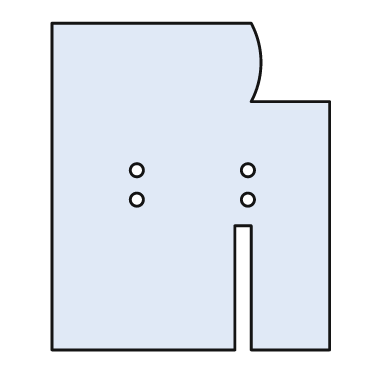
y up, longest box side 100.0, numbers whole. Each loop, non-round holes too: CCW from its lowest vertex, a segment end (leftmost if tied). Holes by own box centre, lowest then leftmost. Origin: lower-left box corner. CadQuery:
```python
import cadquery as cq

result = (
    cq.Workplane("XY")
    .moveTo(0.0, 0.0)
    .lineTo(56.0, 0.0)
    .lineTo(56.0, 38.0)
    .lineTo(61.0, 38.0)
    .lineTo(61.0, 0.0)
    .lineTo(85.0, 0.0)
    .lineTo(85.0, 76.0)
    .lineTo(61.0, 76.0)
    .threePointArc((64.0, 88.0), (61.0, 100.0))
    .lineTo(0.0, 100.0)
    .close()
    .moveTo(26.0, 46.0)
    .circle(2.0)
    .moveTo(60.0, 46.0)
    .circle(2.0)
    .moveTo(26.0, 55.0)
    .circle(2.0)
    .moveTo(60.0, 55.0)
    .circle(2.0)
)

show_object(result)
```